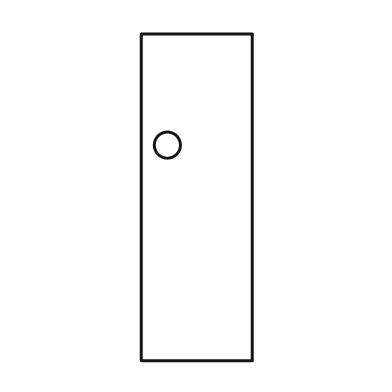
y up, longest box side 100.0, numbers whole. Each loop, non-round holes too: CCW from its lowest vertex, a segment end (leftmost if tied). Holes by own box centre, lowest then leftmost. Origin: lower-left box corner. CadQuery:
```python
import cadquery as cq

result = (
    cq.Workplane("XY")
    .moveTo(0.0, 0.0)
    .lineTo(34.0, 0.0)
    .lineTo(34.0, 100.0)
    .lineTo(0.0, 100.0)
    .close()
    .moveTo(8.0, 66.0)
    .circle(4.0)
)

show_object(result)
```